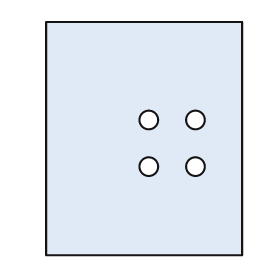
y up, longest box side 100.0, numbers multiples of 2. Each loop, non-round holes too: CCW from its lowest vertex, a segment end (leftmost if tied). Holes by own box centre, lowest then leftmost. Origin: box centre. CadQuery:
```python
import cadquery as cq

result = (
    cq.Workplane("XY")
    .moveTo(-42.0, -50.0)
    .lineTo(42.0, -50.0)
    .lineTo(42.0, 50.0)
    .lineTo(-42.0, 50.0)
    .close()
    .moveTo(2.0, -12.0)
    .circle(4.0)
    .moveTo(22.0, -12.0)
    .circle(4.0)
    .moveTo(2.0, 8.0)
    .circle(4.0)
    .moveTo(22.0, 8.0)
    .circle(4.0)
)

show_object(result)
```